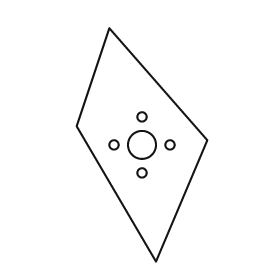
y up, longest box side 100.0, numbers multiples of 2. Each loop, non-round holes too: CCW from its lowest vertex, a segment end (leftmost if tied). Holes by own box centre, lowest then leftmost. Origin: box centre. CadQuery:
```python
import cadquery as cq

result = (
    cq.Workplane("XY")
    .moveTo(6.0, -50.0)
    .lineTo(28.0, 2.0)
    .lineTo(-14.0, 50.0)
    .lineTo(-28.0, 8.0)
    .close()
    .moveTo(0.0, -12.0)
    .circle(2.0)
    .moveTo(-12.0, 0.0)
    .circle(2.0)
    .moveTo(0.0, 0.0)
    .circle(6.0)
    .moveTo(12.0, 0.0)
    .circle(2.0)
    .moveTo(0.0, 12.0)
    .circle(2.0)
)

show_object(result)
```